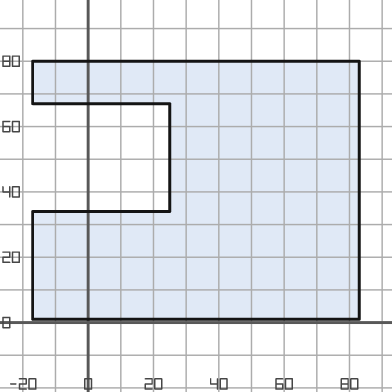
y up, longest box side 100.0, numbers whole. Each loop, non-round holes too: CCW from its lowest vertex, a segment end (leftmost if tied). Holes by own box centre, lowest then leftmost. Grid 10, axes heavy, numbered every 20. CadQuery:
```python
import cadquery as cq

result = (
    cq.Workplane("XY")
    .moveTo(-17.0, 1.0)
    .lineTo(83.0, 1.0)
    .lineTo(83.0, 80.0)
    .lineTo(-17.0, 80.0)
    .lineTo(-17.0, 67.0)
    .lineTo(25.0, 67.0)
    .lineTo(25.0, 34.0)
    .lineTo(-17.0, 34.0)
    .close()
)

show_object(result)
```